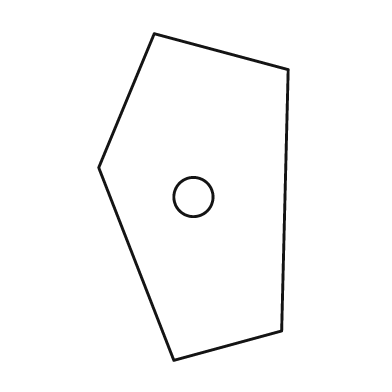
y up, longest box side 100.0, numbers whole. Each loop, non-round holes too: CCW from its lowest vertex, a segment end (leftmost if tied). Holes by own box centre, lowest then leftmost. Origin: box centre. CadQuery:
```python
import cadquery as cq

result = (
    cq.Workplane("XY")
    .moveTo(-6.0, -50.0)
    .lineTo(27.0, -41.0)
    .lineTo(29.0, 39.0)
    .lineTo(-12.0, 50.0)
    .lineTo(-29.0, 9.0)
    .close()
    .moveTo(0.0, 0.0)
    .circle(6.0)
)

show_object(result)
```